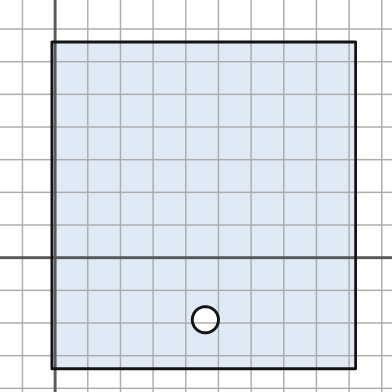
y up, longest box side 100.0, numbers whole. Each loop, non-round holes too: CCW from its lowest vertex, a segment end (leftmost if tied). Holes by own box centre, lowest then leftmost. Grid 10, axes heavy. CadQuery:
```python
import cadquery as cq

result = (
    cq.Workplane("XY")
    .moveTo(-1.0, -34.0)
    .lineTo(92.0, -34.0)
    .lineTo(92.0, 66.0)
    .lineTo(-1.0, 66.0)
    .close()
    .moveTo(46.0, -19.0)
    .circle(4.0)
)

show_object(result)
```